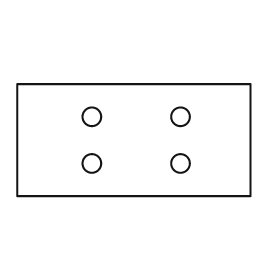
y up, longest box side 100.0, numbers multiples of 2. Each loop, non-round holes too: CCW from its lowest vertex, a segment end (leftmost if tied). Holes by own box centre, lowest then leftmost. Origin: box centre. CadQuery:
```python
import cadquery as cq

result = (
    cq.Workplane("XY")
    .moveTo(-50.0, -24.0)
    .lineTo(50.0, -24.0)
    .lineTo(50.0, 24.0)
    .lineTo(-50.0, 24.0)
    .close()
    .moveTo(-18.0, -10.0)
    .circle(4.0)
    .moveTo(20.0, -10.0)
    .circle(4.0)
    .moveTo(-18.0, 10.0)
    .circle(4.0)
    .moveTo(20.0, 10.0)
    .circle(4.0)
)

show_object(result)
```